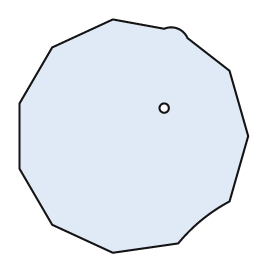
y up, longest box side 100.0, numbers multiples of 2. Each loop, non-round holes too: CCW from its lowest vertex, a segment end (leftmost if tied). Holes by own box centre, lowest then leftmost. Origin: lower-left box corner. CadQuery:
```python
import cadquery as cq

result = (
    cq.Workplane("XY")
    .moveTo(40.0, 0.0)
    .lineTo(68.0, 4.0)
    .threePointArc((78.0, 14.0), (90.0, 22.0))
    .lineTo(98.0, 50.0)
    .lineTo(90.0, 78.0)
    .lineTo(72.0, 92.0)
    .threePointArc((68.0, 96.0), (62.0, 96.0))
    .lineTo(40.0, 100.0)
    .lineTo(14.0, 88.0)
    .lineTo(0.0, 64.0)
    .lineTo(0.0, 36.0)
    .lineTo(14.0, 12.0)
    .close()
    .moveTo(62.0, 62.0)
    .circle(2.0)
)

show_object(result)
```